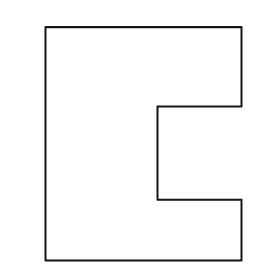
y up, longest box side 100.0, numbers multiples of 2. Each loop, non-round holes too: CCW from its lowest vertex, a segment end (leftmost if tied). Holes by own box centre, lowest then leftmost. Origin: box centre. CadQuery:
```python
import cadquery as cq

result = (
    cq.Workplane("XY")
    .moveTo(-42.0, -50.0)
    .lineTo(42.0, -50.0)
    .lineTo(42.0, -24.0)
    .lineTo(6.0, -24.0)
    .lineTo(6.0, 16.0)
    .lineTo(42.0, 16.0)
    .lineTo(42.0, 50.0)
    .lineTo(-42.0, 50.0)
    .close()
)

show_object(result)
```